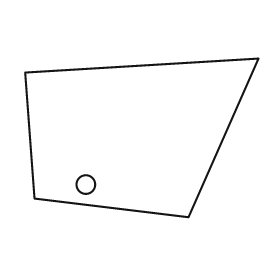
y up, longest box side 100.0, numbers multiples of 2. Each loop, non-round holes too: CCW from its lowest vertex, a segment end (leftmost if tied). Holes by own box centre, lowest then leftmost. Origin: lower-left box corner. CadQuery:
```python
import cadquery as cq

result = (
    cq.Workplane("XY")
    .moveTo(70.0, 0.0)
    .lineTo(100.0, 68.0)
    .lineTo(0.0, 62.0)
    .lineTo(4.0, 8.0)
    .close()
    .moveTo(26.0, 14.0)
    .circle(4.0)
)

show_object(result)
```